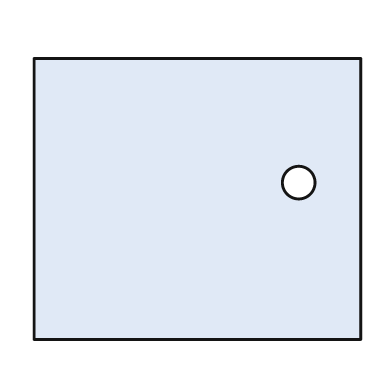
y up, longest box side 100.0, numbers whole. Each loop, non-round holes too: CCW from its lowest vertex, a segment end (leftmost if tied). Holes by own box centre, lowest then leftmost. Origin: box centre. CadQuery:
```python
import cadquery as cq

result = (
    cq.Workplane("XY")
    .moveTo(-50.0, -43.0)
    .lineTo(50.0, -43.0)
    .lineTo(50.0, 43.0)
    .lineTo(-50.0, 43.0)
    .close()
    .moveTo(31.0, 5.0)
    .circle(5.0)
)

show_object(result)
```